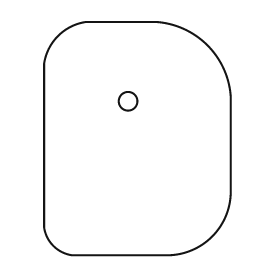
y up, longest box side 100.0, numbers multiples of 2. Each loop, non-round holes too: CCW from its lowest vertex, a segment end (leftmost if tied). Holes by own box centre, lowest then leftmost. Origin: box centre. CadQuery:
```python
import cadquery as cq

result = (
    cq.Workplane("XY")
    .moveTo(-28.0, -50.0)
    .lineTo(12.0, -50.0)
    .threePointArc((32.0, -42.0), (40.0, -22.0))
    .lineTo(40.0, 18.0)
    .threePointArc((30.0, 40.0), (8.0, 50.0))
    .lineTo(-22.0, 50.0)
    .threePointArc((-34.0, 44.0), (-40.0, 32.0))
    .lineTo(-40.0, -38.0)
    .threePointArc((-36.0, -46.0), (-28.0, -50.0))
    .close()
    .moveTo(-4.0, 16.0)
    .circle(4.0)
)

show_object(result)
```